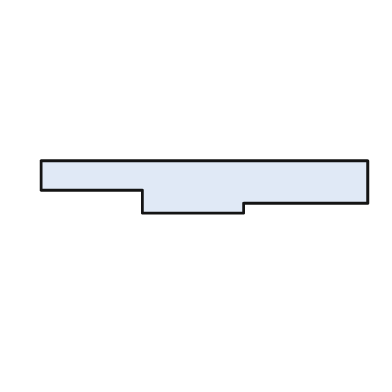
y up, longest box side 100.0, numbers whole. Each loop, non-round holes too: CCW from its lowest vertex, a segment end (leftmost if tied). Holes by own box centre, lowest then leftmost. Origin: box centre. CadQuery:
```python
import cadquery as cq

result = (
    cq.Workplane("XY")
    .moveTo(-19.0, -8.0)
    .lineTo(12.0, -8.0)
    .lineTo(12.0, -5.0)
    .lineTo(50.0, -5.0)
    .lineTo(50.0, 8.0)
    .lineTo(-50.0, 8.0)
    .lineTo(-50.0, -1.0)
    .lineTo(-19.0, -1.0)
    .close()
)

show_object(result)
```